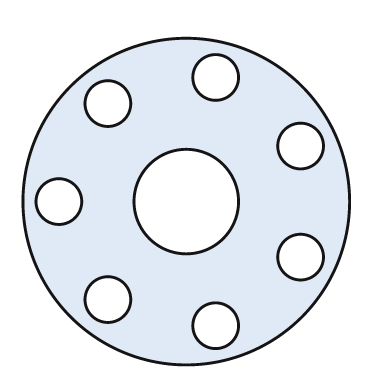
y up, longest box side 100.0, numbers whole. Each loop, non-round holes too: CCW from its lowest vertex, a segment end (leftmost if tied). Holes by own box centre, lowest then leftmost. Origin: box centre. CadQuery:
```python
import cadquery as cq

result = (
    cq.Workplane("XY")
    .moveTo(0.0, 0.0)
    .circle(50.0)
    .moveTo(9.0, -38.0)
    .circle(7.0)
    .moveTo(-24.0, -30.0)
    .circle(7.0)
    .moveTo(35.0, -17.0)
    .circle(7.0)
    .moveTo(-39.0, 0.0)
    .circle(7.0)
    .moveTo(0.0, 0.0)
    .circle(16.0)
    .moveTo(35.0, 17.0)
    .circle(7.0)
    .moveTo(-24.0, 30.0)
    .circle(7.0)
    .moveTo(9.0, 38.0)
    .circle(7.0)
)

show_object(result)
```